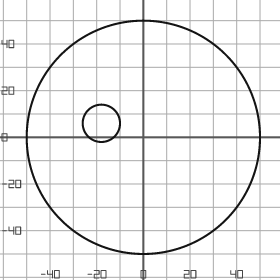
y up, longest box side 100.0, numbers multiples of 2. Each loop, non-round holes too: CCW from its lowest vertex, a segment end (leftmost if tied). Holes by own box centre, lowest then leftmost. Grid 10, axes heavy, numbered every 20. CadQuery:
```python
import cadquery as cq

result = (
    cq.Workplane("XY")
    .moveTo(0.0, 0.0)
    .circle(50.0)
    .moveTo(-18.0, 6.0)
    .circle(8.0)
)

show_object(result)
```